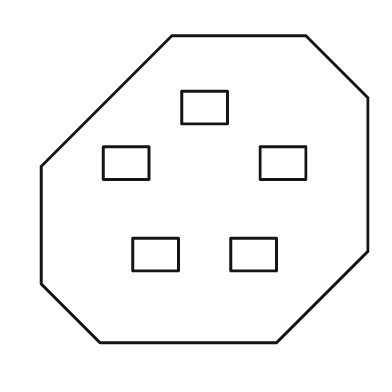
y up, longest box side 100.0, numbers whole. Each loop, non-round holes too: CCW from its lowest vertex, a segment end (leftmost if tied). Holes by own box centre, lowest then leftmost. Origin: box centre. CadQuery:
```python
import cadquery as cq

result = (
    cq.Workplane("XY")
    .moveTo(-32.0, -47.0)
    .lineTo(22.0, -47.0)
    .lineTo(50.0, -19.0)
    .lineTo(50.0, 28.0)
    .lineTo(31.0, 47.0)
    .lineTo(-10.0, 47.0)
    .lineTo(-50.0, 7.0)
    .lineTo(-50.0, -29.0)
    .close()
    .moveTo(-22.0, -25.0)
    .lineTo(-8.0, -25.0)
    .lineTo(-8.0, -15.0)
    .lineTo(-22.0, -15.0)
    .close()
    .moveTo(8.0, -25.0)
    .lineTo(22.0, -25.0)
    .lineTo(22.0, -15.0)
    .lineTo(8.0, -15.0)
    .close()
    .moveTo(-31.0, 3.0)
    .lineTo(-17.0, 3.0)
    .lineTo(-17.0, 13.0)
    .lineTo(-31.0, 13.0)
    .close()
    .moveTo(17.0, 3.0)
    .lineTo(31.0, 3.0)
    .lineTo(31.0, 13.0)
    .lineTo(17.0, 13.0)
    .close()
    .moveTo(-7.0, 20.0)
    .lineTo(7.0, 20.0)
    .lineTo(7.0, 30.0)
    .lineTo(-7.0, 30.0)
    .close()
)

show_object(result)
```